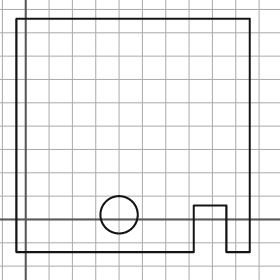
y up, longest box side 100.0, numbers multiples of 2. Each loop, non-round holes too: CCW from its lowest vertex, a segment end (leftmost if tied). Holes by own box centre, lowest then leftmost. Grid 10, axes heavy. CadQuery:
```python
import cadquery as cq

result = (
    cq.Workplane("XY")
    .moveTo(-4.0, -14.0)
    .lineTo(72.0, -14.0)
    .lineTo(72.0, 6.0)
    .lineTo(86.0, 6.0)
    .lineTo(86.0, -14.0)
    .lineTo(96.0, -14.0)
    .lineTo(96.0, 86.0)
    .lineTo(-4.0, 86.0)
    .close()
    .moveTo(40.0, 2.0)
    .circle(8.0)
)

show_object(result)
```